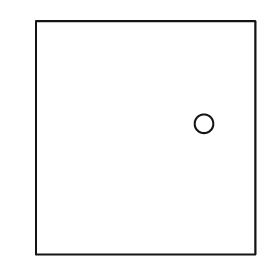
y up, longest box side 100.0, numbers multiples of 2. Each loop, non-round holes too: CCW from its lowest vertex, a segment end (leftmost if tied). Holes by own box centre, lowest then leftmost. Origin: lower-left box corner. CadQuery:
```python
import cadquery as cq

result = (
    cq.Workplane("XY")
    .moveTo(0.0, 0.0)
    .lineTo(94.0, 0.0)
    .lineTo(94.0, 100.0)
    .lineTo(0.0, 100.0)
    .close()
    .moveTo(72.0, 56.0)
    .circle(4.0)
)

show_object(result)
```